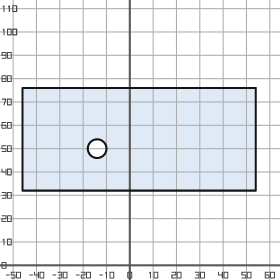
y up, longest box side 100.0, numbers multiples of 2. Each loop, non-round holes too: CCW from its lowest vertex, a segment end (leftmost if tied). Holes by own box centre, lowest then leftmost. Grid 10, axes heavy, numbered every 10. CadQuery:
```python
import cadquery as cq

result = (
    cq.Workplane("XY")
    .moveTo(-46.0, 32.0)
    .lineTo(54.0, 32.0)
    .lineTo(54.0, 76.0)
    .lineTo(-46.0, 76.0)
    .close()
    .moveTo(-14.0, 50.0)
    .circle(4.0)
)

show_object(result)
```